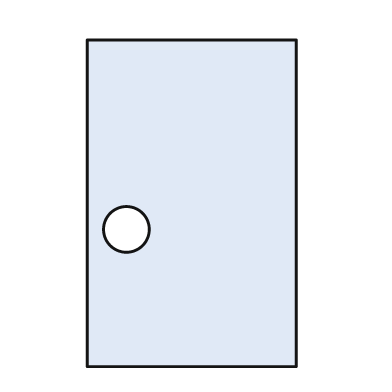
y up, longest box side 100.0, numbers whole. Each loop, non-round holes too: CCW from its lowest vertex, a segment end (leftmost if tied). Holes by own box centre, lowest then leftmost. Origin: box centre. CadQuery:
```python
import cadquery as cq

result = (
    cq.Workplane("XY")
    .moveTo(-32.0, -50.0)
    .lineTo(32.0, -50.0)
    .lineTo(32.0, 50.0)
    .lineTo(-32.0, 50.0)
    .close()
    .moveTo(-20.0, -8.0)
    .circle(7.0)
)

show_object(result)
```